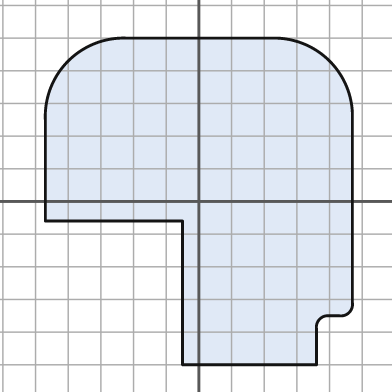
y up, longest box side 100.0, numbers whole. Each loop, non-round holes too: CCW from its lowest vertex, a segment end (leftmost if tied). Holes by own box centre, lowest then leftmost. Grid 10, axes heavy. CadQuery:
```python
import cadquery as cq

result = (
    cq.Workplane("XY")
    .moveTo(-5.0, -50.0)
    .lineTo(36.0, -50.0)
    .lineTo(36.0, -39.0)
    .threePointArc((37.0, -36.0), (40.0, -35.0))
    .lineTo(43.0, -35.0)
    .threePointArc((46.0, -34.0), (47.0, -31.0))
    .lineTo(47.0, 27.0)
    .threePointArc((40.0, 43.0), (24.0, 50.0))
    .lineTo(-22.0, 50.0)
    .threePointArc((-40.0, 43.0), (-47.0, 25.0))
    .lineTo(-47.0, -6.0)
    .lineTo(-5.0, -6.0)
    .close()
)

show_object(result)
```